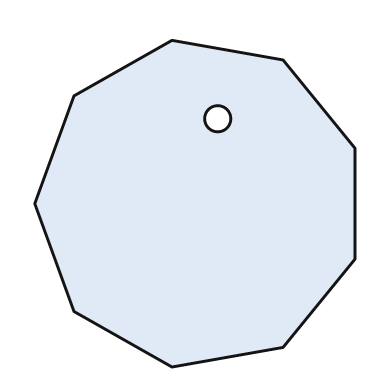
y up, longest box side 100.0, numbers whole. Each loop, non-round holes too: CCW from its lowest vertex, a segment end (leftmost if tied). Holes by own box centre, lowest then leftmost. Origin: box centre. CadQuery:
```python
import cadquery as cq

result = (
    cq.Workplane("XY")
    .moveTo(-7.0, -50.0)
    .lineTo(27.0, -44.0)
    .lineTo(49.0, -17.0)
    .lineTo(49.0, 17.0)
    .lineTo(27.0, 44.0)
    .lineTo(-7.0, 50.0)
    .lineTo(-37.0, 33.0)
    .lineTo(-49.0, 0.0)
    .lineTo(-37.0, -33.0)
    .close()
    .moveTo(7.0, 26.0)
    .circle(4.0)
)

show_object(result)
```